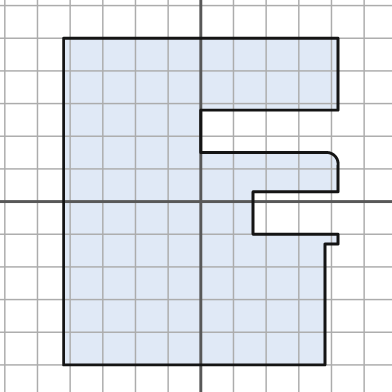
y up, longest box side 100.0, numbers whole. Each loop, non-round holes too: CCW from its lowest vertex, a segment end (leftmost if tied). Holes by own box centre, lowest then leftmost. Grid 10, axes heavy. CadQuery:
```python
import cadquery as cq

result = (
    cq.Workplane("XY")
    .moveTo(-42.0, -50.0)
    .lineTo(38.0, -50.0)
    .lineTo(38.0, -13.0)
    .lineTo(42.0, -13.0)
    .lineTo(42.0, -10.0)
    .lineTo(16.0, -10.0)
    .lineTo(16.0, 3.0)
    .lineTo(42.0, 3.0)
    .lineTo(42.0, 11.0)
    .threePointArc((41.0, 14.0), (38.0, 15.0))
    .lineTo(0.0, 15.0)
    .lineTo(0.0, 28.0)
    .lineTo(42.0, 28.0)
    .lineTo(42.0, 50.0)
    .lineTo(-42.0, 50.0)
    .close()
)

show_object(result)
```